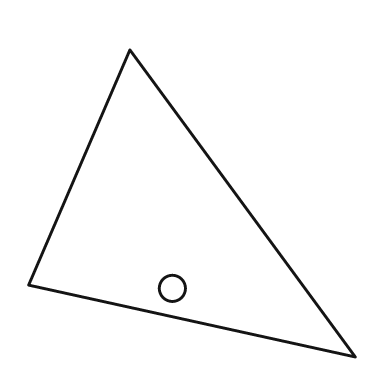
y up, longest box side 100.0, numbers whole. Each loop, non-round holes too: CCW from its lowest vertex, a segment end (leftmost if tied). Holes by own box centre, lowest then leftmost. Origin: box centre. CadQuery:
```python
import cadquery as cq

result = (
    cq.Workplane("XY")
    .moveTo(50.0, -47.0)
    .lineTo(-19.0, 47.0)
    .lineTo(-50.0, -25.0)
    .close()
    .moveTo(-6.0, -26.0)
    .circle(4.0)
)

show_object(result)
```